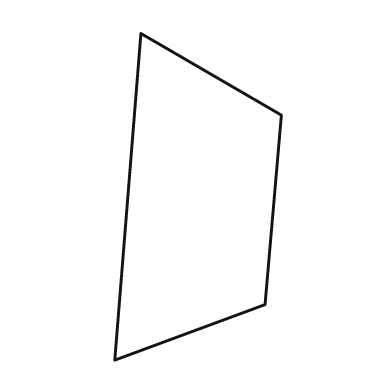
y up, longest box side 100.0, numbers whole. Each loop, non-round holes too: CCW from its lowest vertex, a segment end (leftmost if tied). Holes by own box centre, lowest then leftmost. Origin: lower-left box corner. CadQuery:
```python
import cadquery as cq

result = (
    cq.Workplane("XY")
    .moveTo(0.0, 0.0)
    .lineTo(46.0, 17.0)
    .lineTo(51.0, 75.0)
    .lineTo(8.0, 100.0)
    .close()
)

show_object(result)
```